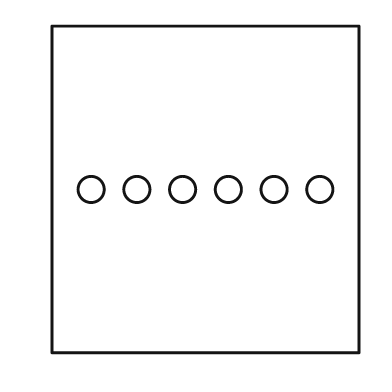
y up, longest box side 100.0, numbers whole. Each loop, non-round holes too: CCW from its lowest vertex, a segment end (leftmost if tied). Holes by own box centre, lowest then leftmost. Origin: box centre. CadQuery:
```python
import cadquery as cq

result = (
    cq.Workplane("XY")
    .moveTo(-47.0, -50.0)
    .lineTo(47.0, -50.0)
    .lineTo(47.0, 50.0)
    .lineTo(-47.0, 50.0)
    .close()
    .moveTo(-35.0, 0.0)
    .circle(4.0)
    .moveTo(-21.0, 0.0)
    .circle(4.0)
    .moveTo(-7.0, 0.0)
    .circle(4.0)
    .moveTo(7.0, 0.0)
    .circle(4.0)
    .moveTo(21.0, 0.0)
    .circle(4.0)
    .moveTo(35.0, 0.0)
    .circle(4.0)
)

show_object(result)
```